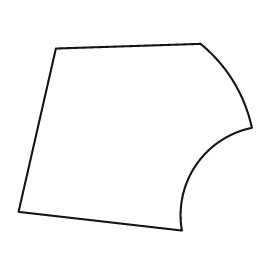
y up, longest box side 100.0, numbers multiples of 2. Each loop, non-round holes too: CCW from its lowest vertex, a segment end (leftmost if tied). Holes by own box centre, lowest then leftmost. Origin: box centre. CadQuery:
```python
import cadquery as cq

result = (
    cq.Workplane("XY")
    .moveTo(20.0, -40.0)
    .threePointArc((26.0, -12.0), (50.0, 4.0))
    .threePointArc((42.0, 24.0), (28.0, 40.0))
    .lineTo(-34.0, 38.0)
    .lineTo(-50.0, -32.0)
    .close()
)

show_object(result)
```